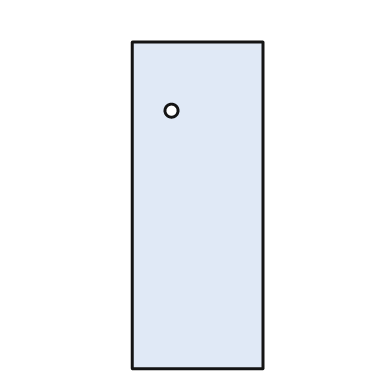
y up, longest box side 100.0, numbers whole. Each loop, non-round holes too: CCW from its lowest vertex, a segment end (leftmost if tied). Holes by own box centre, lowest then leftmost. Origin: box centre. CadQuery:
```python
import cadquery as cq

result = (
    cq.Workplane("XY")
    .moveTo(-20.0, -50.0)
    .lineTo(20.0, -50.0)
    .lineTo(20.0, 50.0)
    .lineTo(-20.0, 50.0)
    .close()
    .moveTo(-8.0, 29.0)
    .circle(2.0)
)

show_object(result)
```